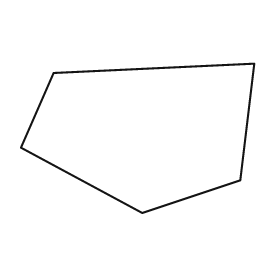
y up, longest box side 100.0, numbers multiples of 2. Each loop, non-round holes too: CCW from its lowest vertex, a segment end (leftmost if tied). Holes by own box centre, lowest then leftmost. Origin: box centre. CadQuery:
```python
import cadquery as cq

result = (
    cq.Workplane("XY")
    .moveTo(2.0, -32.0)
    .lineTo(44.0, -18.0)
    .lineTo(50.0, 32.0)
    .lineTo(-36.0, 28.0)
    .lineTo(-50.0, -4.0)
    .close()
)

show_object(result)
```